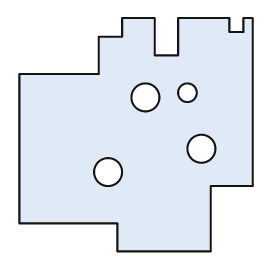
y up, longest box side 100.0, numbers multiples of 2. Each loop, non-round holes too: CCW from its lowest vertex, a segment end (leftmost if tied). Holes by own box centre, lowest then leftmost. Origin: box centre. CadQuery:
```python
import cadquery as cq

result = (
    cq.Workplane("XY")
    .moveTo(-8.0, -50.0)
    .lineTo(32.0, -50.0)
    .lineTo(32.0, -22.0)
    .lineTo(50.0, -22.0)
    .lineTo(50.0, 50.0)
    .lineTo(46.0, 50.0)
    .lineTo(46.0, 44.0)
    .lineTo(40.0, 44.0)
    .lineTo(40.0, 50.0)
    .lineTo(18.0, 50.0)
    .lineTo(18.0, 34.0)
    .lineTo(8.0, 34.0)
    .lineTo(8.0, 50.0)
    .lineTo(-6.0, 50.0)
    .lineTo(-6.0, 42.0)
    .lineTo(-16.0, 42.0)
    .lineTo(-16.0, 26.0)
    .lineTo(-50.0, 26.0)
    .lineTo(-50.0, -38.0)
    .lineTo(-8.0, -38.0)
    .close()
    .moveTo(-12.0, -16.0)
    .circle(6.0)
    .moveTo(28.0, -6.0)
    .circle(6.0)
    .moveTo(4.0, 16.0)
    .circle(6.0)
    .moveTo(22.0, 18.0)
    .circle(4.0)
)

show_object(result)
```